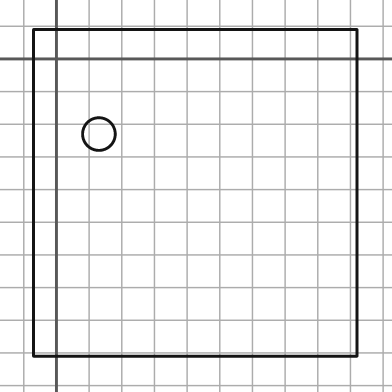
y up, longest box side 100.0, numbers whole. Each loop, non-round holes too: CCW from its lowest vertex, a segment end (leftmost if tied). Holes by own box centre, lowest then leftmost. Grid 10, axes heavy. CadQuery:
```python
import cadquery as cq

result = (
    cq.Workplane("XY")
    .moveTo(-7.0, -91.0)
    .lineTo(92.0, -91.0)
    .lineTo(92.0, 9.0)
    .lineTo(-7.0, 9.0)
    .close()
    .moveTo(13.0, -23.0)
    .circle(5.0)
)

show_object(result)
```